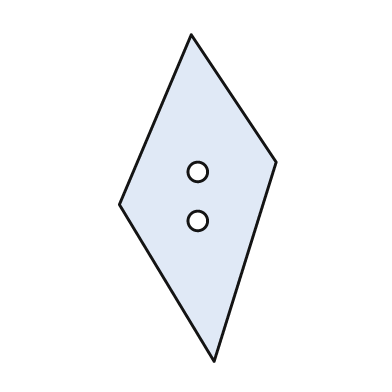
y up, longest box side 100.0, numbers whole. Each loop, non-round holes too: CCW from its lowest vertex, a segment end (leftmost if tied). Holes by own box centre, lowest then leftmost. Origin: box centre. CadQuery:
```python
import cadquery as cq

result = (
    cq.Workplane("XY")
    .moveTo(5.0, -50.0)
    .lineTo(24.0, 11.0)
    .lineTo(-2.0, 50.0)
    .lineTo(-24.0, -2.0)
    .close()
    .moveTo(0.0, -7.0)
    .circle(3.0)
    .moveTo(0.0, 8.0)
    .circle(3.0)
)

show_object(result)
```